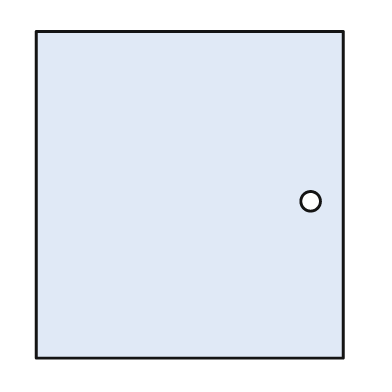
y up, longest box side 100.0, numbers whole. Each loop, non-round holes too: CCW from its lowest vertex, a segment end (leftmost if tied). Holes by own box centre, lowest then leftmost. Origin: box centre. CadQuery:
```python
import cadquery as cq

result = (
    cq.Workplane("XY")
    .moveTo(-47.0, -50.0)
    .lineTo(47.0, -50.0)
    .lineTo(47.0, 50.0)
    .lineTo(-47.0, 50.0)
    .close()
    .moveTo(37.0, -2.0)
    .circle(3.0)
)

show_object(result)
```